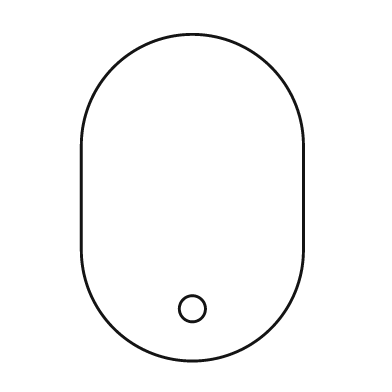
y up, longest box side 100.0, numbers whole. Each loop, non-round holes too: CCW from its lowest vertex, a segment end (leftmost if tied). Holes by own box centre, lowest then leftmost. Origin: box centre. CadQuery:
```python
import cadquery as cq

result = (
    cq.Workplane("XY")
    .moveTo(-34.0, -16.0)
    .threePointArc((0.0, -50.0), (34.0, -16.0))
    .lineTo(34.0, 16.0)
    .threePointArc((0.0, 50.0), (-34.0, 16.0))
    .close()
    .moveTo(0.0, -34.0)
    .circle(4.0)
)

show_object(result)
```